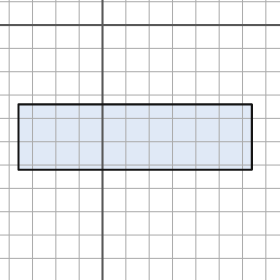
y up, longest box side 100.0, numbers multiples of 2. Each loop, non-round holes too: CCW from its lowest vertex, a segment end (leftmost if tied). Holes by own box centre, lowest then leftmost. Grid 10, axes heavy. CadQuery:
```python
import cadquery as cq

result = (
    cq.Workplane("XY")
    .moveTo(-36.0, -62.0)
    .lineTo(64.0, -62.0)
    .lineTo(64.0, -34.0)
    .lineTo(-36.0, -34.0)
    .close()
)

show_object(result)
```